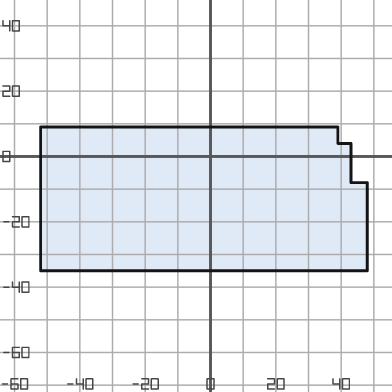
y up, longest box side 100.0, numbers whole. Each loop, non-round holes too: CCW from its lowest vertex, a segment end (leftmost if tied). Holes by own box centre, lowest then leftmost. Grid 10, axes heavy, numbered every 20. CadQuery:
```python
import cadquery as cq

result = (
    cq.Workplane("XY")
    .moveTo(-52.0, -35.0)
    .lineTo(48.0, -35.0)
    .lineTo(48.0, -8.0)
    .lineTo(43.0, -8.0)
    .lineTo(43.0, 4.0)
    .lineTo(39.0, 4.0)
    .lineTo(39.0, 9.0)
    .lineTo(-52.0, 9.0)
    .close()
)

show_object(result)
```